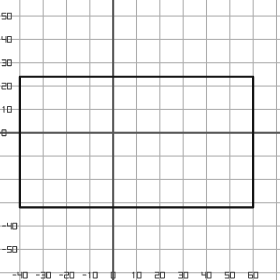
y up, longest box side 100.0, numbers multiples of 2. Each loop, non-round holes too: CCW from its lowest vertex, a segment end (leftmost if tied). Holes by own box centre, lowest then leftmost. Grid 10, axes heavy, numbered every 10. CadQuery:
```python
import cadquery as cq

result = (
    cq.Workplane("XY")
    .moveTo(-40.0, -32.0)
    .lineTo(60.0, -32.0)
    .lineTo(60.0, 24.0)
    .lineTo(-40.0, 24.0)
    .close()
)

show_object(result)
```